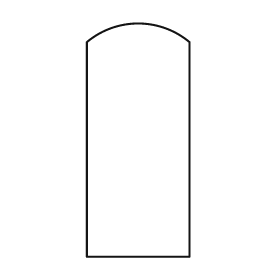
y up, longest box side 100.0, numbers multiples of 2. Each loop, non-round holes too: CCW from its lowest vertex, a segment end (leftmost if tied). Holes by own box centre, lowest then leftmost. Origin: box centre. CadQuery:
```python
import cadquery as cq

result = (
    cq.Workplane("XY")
    .moveTo(-22.0, -50.0)
    .lineTo(22.0, -50.0)
    .lineTo(22.0, 42.0)
    .threePointArc((0.0, 50.0), (-22.0, 42.0))
    .close()
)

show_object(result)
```